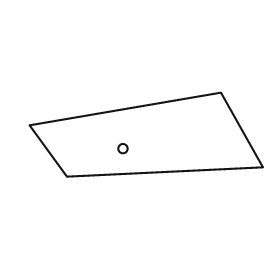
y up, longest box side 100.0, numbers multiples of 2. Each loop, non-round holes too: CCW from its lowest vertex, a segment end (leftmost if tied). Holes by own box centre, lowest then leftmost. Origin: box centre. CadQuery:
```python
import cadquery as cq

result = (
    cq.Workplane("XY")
    .moveTo(-34.0, -18.0)
    .lineTo(50.0, -14.0)
    .lineTo(32.0, 18.0)
    .lineTo(-50.0, 4.0)
    .close()
    .moveTo(-10.0, -6.0)
    .circle(2.0)
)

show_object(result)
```